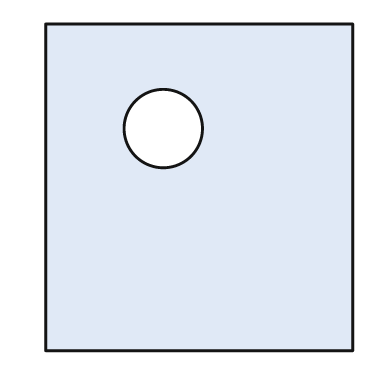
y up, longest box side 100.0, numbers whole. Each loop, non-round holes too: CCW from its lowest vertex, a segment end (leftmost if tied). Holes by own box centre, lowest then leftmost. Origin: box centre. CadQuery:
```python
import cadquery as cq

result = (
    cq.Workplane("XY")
    .moveTo(-47.0, -50.0)
    .lineTo(47.0, -50.0)
    .lineTo(47.0, 50.0)
    .lineTo(-47.0, 50.0)
    .close()
    .moveTo(-11.0, 18.0)
    .circle(12.0)
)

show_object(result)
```